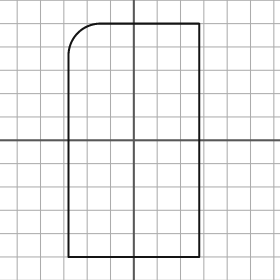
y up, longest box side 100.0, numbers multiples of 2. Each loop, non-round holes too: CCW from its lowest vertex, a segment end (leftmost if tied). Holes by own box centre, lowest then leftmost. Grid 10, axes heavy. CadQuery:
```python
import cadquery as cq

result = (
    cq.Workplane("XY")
    .moveTo(-28.0, -50.0)
    .lineTo(28.0, -50.0)
    .lineTo(28.0, 50.0)
    .lineTo(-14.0, 50.0)
    .threePointArc((-24.0, 46.0), (-28.0, 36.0))
    .close()
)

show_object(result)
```